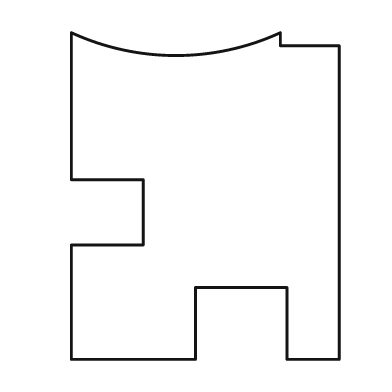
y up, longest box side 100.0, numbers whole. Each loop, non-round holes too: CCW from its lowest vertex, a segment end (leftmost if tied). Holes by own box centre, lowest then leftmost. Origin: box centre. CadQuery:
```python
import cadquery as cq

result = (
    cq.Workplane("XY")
    .moveTo(-41.0, -50.0)
    .lineTo(-3.0, -50.0)
    .lineTo(-3.0, -28.0)
    .lineTo(25.0, -28.0)
    .lineTo(25.0, -50.0)
    .lineTo(41.0, -50.0)
    .lineTo(41.0, 46.0)
    .lineTo(23.0, 46.0)
    .lineTo(23.0, 50.0)
    .threePointArc((-9.0, 43.0), (-41.0, 50.0))
    .lineTo(-41.0, 5.0)
    .lineTo(-19.0, 5.0)
    .lineTo(-19.0, -15.0)
    .lineTo(-41.0, -15.0)
    .close()
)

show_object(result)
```